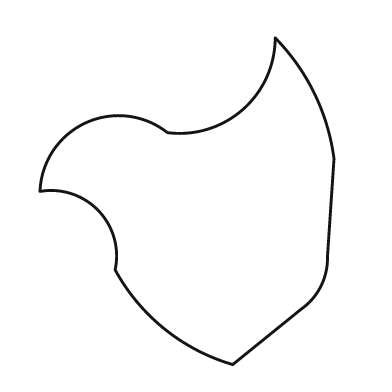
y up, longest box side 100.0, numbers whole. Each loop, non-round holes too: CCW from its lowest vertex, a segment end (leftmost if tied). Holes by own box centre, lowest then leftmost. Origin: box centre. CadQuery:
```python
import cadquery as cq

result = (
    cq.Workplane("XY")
    .moveTo(14.0, -50.0)
    .lineTo(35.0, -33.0)
    .threePointArc((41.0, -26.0), (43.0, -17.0))
    .lineTo(45.0, 13.0)
    .threePointArc((39.0, 33.0), (27.0, 50.0))
    .threePointArc((17.0, 28.0), (-6.0, 21.0))
    .threePointArc((-31.0, 24.0), (-45.0, 3.0))
    .threePointArc((-27.0, -3.0), (-22.0, -21.0))
    .threePointArc((-7.0, -39.0), (14.0, -50.0))
    .close()
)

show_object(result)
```